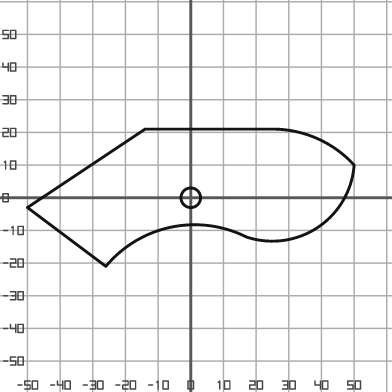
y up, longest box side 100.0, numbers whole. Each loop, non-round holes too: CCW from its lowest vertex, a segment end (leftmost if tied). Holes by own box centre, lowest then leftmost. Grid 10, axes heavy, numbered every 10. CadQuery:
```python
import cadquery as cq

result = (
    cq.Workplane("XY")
    .moveTo(-26.0, -21.0)
    .threePointArc((-6.0, -9.0), (17.0, -12.0))
    .threePointArc((39.0, -9.0), (50.0, 10.0))
    .threePointArc((39.0, 18.0), (26.0, 21.0))
    .lineTo(-14.0, 21.0)
    .lineTo(-50.0, -3.0)
    .close()
    .moveTo(0.0, 0.0)
    .circle(3.0)
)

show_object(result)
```